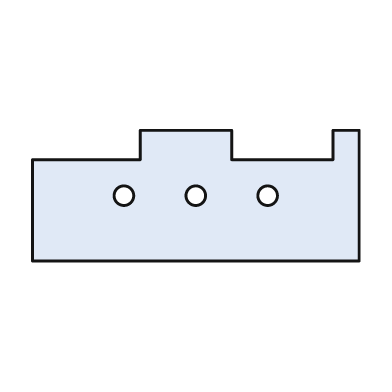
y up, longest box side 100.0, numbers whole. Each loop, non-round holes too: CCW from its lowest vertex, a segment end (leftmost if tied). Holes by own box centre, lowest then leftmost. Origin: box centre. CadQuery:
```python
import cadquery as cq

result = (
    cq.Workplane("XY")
    .moveTo(-50.0, -20.0)
    .lineTo(50.0, -20.0)
    .lineTo(50.0, 20.0)
    .lineTo(42.0, 20.0)
    .lineTo(42.0, 11.0)
    .lineTo(11.0, 11.0)
    .lineTo(11.0, 20.0)
    .lineTo(-17.0, 20.0)
    .lineTo(-17.0, 11.0)
    .lineTo(-50.0, 11.0)
    .close()
    .moveTo(-22.0, 0.0)
    .circle(3.0)
    .moveTo(0.0, 0.0)
    .circle(3.0)
    .moveTo(22.0, 0.0)
    .circle(3.0)
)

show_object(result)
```